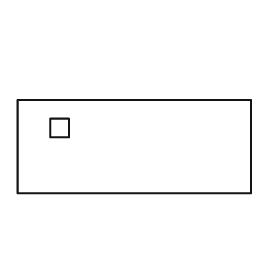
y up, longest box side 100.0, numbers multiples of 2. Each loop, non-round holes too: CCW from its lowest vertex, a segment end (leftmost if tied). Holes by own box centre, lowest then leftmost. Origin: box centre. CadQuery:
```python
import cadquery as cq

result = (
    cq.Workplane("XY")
    .moveTo(-50.0, -20.0)
    .lineTo(50.0, -20.0)
    .lineTo(50.0, 20.0)
    .lineTo(-50.0, 20.0)
    .close()
    .moveTo(-36.0, 4.0)
    .lineTo(-28.0, 4.0)
    .lineTo(-28.0, 12.0)
    .lineTo(-36.0, 12.0)
    .close()
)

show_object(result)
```